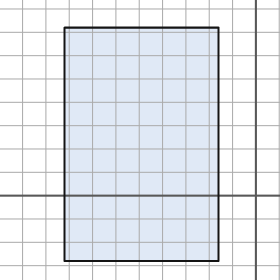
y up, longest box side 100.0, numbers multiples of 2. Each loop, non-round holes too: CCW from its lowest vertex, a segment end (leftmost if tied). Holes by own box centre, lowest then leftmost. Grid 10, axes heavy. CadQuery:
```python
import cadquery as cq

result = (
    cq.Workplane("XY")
    .moveTo(-82.0, -28.0)
    .lineTo(-16.0, -28.0)
    .lineTo(-16.0, 72.0)
    .lineTo(-82.0, 72.0)
    .close()
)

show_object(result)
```